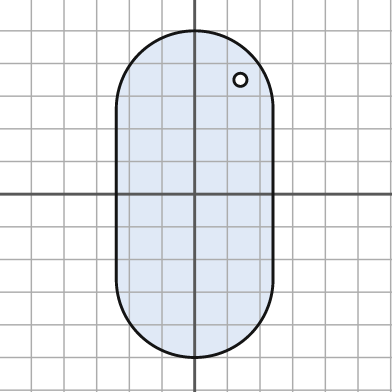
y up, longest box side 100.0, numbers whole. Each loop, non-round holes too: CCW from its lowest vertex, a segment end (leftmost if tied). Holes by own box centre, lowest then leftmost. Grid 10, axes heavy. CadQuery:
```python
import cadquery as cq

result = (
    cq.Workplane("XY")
    .moveTo(-24.0, -26.0)
    .threePointArc((0.0, -50.0), (24.0, -26.0))
    .lineTo(24.0, 26.0)
    .threePointArc((0.0, 50.0), (-24.0, 26.0))
    .close()
    .moveTo(14.0, 35.0)
    .circle(2.0)
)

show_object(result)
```